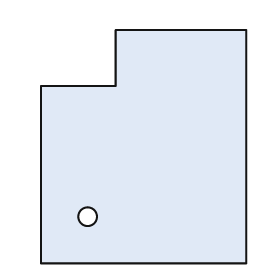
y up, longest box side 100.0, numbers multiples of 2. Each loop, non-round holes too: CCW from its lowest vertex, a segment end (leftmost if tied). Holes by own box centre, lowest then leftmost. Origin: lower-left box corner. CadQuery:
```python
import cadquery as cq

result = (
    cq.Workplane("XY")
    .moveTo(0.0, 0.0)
    .lineTo(88.0, 0.0)
    .lineTo(88.0, 100.0)
    .lineTo(32.0, 100.0)
    .lineTo(32.0, 76.0)
    .lineTo(0.0, 76.0)
    .close()
    .moveTo(20.0, 20.0)
    .circle(4.0)
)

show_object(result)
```